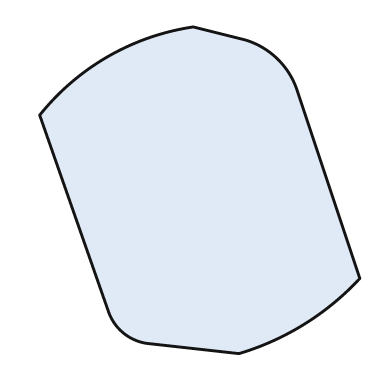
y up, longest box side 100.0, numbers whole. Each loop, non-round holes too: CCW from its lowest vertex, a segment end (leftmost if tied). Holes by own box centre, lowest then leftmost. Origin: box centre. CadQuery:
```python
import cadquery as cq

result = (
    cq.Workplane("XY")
    .moveTo(12.0, -50.0)
    .threePointArc((32.0, -41.0), (49.0, -27.0))
    .lineTo(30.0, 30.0)
    .threePointArc((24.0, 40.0), (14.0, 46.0))
    .lineTo(-2.0, 50.0)
    .threePointArc((-28.0, 41.0), (-49.0, 23.0))
    .lineTo(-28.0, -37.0)
    .threePointArc((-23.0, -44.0), (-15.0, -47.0))
    .close()
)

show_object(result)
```